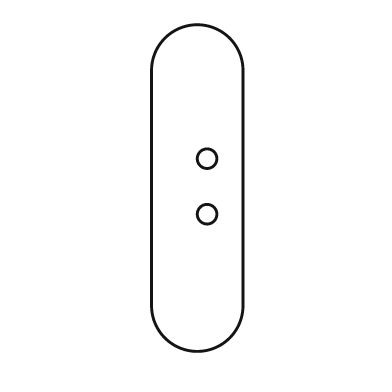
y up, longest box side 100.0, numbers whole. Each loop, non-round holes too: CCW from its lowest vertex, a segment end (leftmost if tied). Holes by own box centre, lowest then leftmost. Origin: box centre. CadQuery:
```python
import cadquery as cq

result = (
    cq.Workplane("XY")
    .moveTo(-14.0, -36.0)
    .threePointArc((0.0, -50.0), (14.0, -36.0))
    .lineTo(14.0, 36.0)
    .threePointArc((0.0, 50.0), (-14.0, 36.0))
    .close()
    .moveTo(3.0, -8.0)
    .circle(3.0)
    .moveTo(3.0, 9.0)
    .circle(3.0)
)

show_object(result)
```